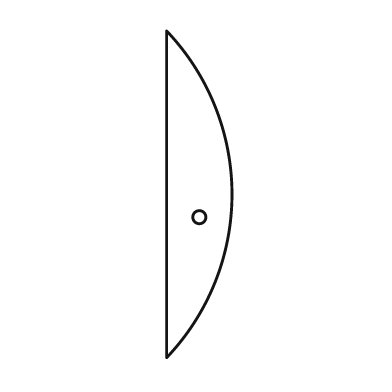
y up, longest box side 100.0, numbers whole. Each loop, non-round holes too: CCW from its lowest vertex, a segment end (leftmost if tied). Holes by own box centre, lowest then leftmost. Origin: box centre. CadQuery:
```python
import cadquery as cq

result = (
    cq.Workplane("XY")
    .moveTo(-10.0, -50.0)
    .threePointArc((10.0, 0.0), (-10.0, 50.0))
    .close()
    .moveTo(0.0, -7.0)
    .circle(2.0)
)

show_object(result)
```